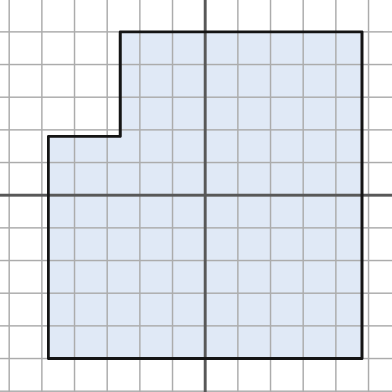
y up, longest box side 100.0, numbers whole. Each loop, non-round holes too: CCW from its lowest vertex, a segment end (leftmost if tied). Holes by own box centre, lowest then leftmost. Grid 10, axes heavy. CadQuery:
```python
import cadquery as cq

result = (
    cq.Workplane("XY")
    .moveTo(-48.0, -50.0)
    .lineTo(48.0, -50.0)
    .lineTo(48.0, 50.0)
    .lineTo(-26.0, 50.0)
    .lineTo(-26.0, 18.0)
    .lineTo(-48.0, 18.0)
    .close()
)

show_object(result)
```